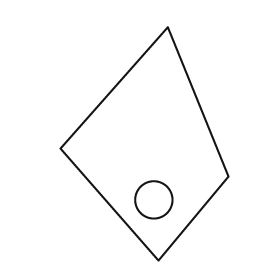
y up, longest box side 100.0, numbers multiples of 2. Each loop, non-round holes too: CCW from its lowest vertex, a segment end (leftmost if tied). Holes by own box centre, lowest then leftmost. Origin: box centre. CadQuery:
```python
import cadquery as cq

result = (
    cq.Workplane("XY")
    .moveTo(6.0, -50.0)
    .lineTo(36.0, -14.0)
    .lineTo(10.0, 50.0)
    .lineTo(-36.0, -2.0)
    .close()
    .moveTo(4.0, -24.0)
    .circle(8.0)
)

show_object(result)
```